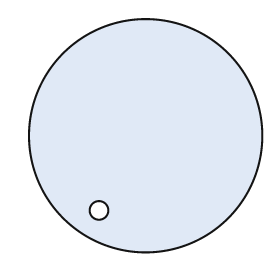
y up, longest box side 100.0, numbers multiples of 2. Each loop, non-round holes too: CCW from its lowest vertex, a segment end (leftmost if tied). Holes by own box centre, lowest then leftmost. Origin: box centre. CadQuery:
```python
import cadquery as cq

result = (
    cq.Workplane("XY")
    .moveTo(0.0, 0.0)
    .circle(50.0)
    .moveTo(-20.0, -32.0)
    .circle(4.0)
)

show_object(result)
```